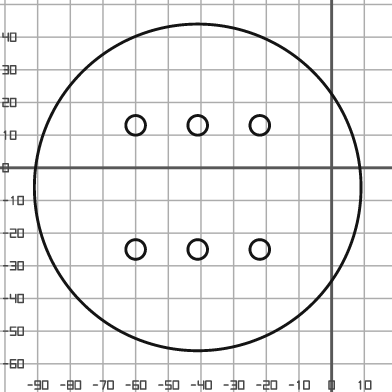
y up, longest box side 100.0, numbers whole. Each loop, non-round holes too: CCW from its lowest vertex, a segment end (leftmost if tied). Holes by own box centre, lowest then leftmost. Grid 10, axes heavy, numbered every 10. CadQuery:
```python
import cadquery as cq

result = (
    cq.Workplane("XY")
    .moveTo(-41.0, -6.0)
    .circle(50.0)
    .moveTo(-60.0, -25.0)
    .circle(3.0)
    .moveTo(-41.0, -25.0)
    .circle(3.0)
    .moveTo(-22.0, -25.0)
    .circle(3.0)
    .moveTo(-60.0, 13.0)
    .circle(3.0)
    .moveTo(-41.0, 13.0)
    .circle(3.0)
    .moveTo(-22.0, 13.0)
    .circle(3.0)
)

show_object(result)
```